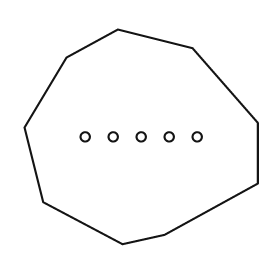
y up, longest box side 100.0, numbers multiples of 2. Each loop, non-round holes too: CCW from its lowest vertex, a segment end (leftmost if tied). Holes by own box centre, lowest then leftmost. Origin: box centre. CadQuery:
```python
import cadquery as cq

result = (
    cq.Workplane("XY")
    .moveTo(-8.0, -46.0)
    .lineTo(10.0, -42.0)
    .lineTo(50.0, -20.0)
    .lineTo(50.0, 6.0)
    .lineTo(22.0, 38.0)
    .lineTo(-10.0, 46.0)
    .lineTo(-32.0, 34.0)
    .lineTo(-50.0, 4.0)
    .lineTo(-42.0, -28.0)
    .close()
    .moveTo(-24.0, 0.0)
    .circle(2.0)
    .moveTo(-12.0, 0.0)
    .circle(2.0)
    .moveTo(0.0, 0.0)
    .circle(2.0)
    .moveTo(12.0, 0.0)
    .circle(2.0)
    .moveTo(24.0, 0.0)
    .circle(2.0)
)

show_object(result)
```